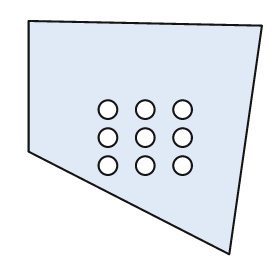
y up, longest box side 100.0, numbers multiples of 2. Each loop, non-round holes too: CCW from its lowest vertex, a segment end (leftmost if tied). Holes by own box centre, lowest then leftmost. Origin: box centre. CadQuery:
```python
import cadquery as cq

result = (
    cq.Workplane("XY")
    .moveTo(36.0, -50.0)
    .lineTo(50.0, 48.0)
    .lineTo(-50.0, 50.0)
    .lineTo(-50.0, -6.0)
    .close()
    .moveTo(-16.0, -12.0)
    .circle(4.0)
    .moveTo(0.0, -12.0)
    .circle(4.0)
    .moveTo(16.0, -12.0)
    .circle(4.0)
    .moveTo(-16.0, 0.0)
    .circle(4.0)
    .moveTo(0.0, 0.0)
    .circle(4.0)
    .moveTo(16.0, 0.0)
    .circle(4.0)
    .moveTo(-16.0, 12.0)
    .circle(4.0)
    .moveTo(0.0, 12.0)
    .circle(4.0)
    .moveTo(16.0, 12.0)
    .circle(4.0)
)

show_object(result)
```